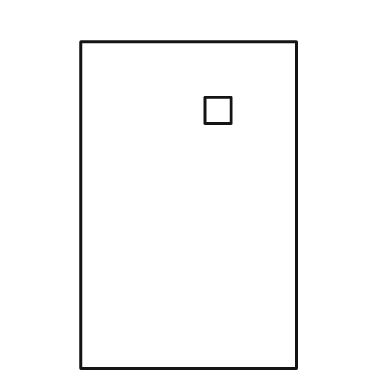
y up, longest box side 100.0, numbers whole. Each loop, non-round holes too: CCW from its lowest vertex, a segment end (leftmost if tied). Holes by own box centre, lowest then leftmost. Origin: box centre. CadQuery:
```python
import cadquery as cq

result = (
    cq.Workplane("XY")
    .moveTo(-33.0, -50.0)
    .lineTo(33.0, -50.0)
    .lineTo(33.0, 50.0)
    .lineTo(-33.0, 50.0)
    .close()
    .moveTo(5.0, 25.0)
    .lineTo(13.0, 25.0)
    .lineTo(13.0, 33.0)
    .lineTo(5.0, 33.0)
    .close()
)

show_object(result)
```